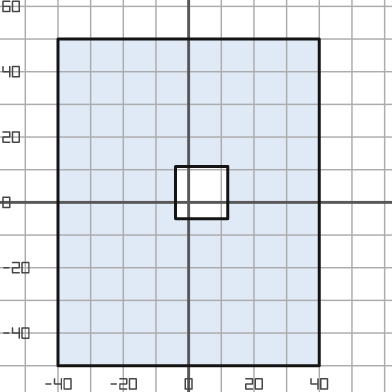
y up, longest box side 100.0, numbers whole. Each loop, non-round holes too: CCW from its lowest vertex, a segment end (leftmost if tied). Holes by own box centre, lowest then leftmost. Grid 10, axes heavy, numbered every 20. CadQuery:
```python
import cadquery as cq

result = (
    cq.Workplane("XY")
    .moveTo(-40.0, -50.0)
    .lineTo(40.0, -50.0)
    .lineTo(40.0, 50.0)
    .lineTo(-40.0, 50.0)
    .close()
    .moveTo(-4.0, -5.0)
    .lineTo(12.0, -5.0)
    .lineTo(12.0, 11.0)
    .lineTo(-4.0, 11.0)
    .close()
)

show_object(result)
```